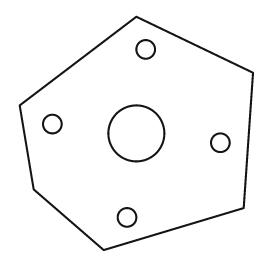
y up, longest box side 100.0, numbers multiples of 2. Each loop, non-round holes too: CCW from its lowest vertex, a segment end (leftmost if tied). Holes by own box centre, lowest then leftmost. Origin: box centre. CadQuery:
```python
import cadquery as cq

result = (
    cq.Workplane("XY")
    .moveTo(-14.0, -50.0)
    .lineTo(46.0, -32.0)
    .lineTo(50.0, 26.0)
    .lineTo(0.0, 50.0)
    .lineTo(-50.0, 12.0)
    .lineTo(-44.0, -24.0)
    .close()
    .moveTo(-4.0, -36.0)
    .circle(4.0)
    .moveTo(36.0, -4.0)
    .circle(4.0)
    .moveTo(0.0, 0.0)
    .circle(12.0)
    .moveTo(-36.0, 4.0)
    .circle(4.0)
    .moveTo(4.0, 36.0)
    .circle(4.0)
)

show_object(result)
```